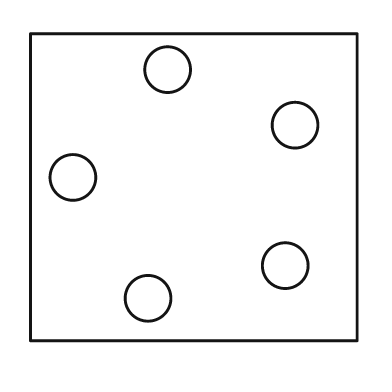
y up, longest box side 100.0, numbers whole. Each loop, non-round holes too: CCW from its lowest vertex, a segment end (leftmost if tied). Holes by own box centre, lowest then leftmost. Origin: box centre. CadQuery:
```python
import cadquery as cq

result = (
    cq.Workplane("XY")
    .moveTo(-50.0, -47.0)
    .lineTo(50.0, -47.0)
    .lineTo(50.0, 47.0)
    .lineTo(-50.0, 47.0)
    .close()
    .moveTo(-14.0, -34.0)
    .circle(7.0)
    .moveTo(28.0, -24.0)
    .circle(7.0)
    .moveTo(-37.0, 3.0)
    .circle(7.0)
    .moveTo(31.0, 19.0)
    .circle(7.0)
    .moveTo(-8.0, 36.0)
    .circle(7.0)
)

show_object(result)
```